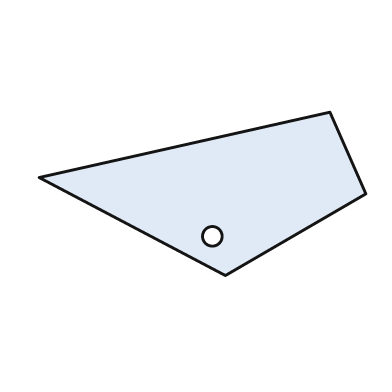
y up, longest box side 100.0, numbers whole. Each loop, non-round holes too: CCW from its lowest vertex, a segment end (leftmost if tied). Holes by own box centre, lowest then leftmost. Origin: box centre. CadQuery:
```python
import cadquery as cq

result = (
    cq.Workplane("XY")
    .moveTo(7.0, -25.0)
    .lineTo(50.0, 0.0)
    .lineTo(39.0, 25.0)
    .lineTo(-50.0, 5.0)
    .close()
    .moveTo(3.0, -13.0)
    .circle(3.0)
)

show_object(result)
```